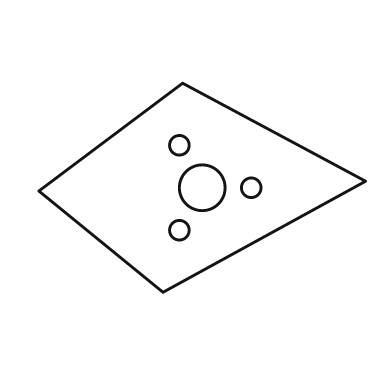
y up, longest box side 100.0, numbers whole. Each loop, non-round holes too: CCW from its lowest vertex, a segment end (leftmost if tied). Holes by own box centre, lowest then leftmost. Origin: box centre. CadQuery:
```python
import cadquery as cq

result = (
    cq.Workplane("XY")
    .moveTo(-12.0, -32.0)
    .lineTo(50.0, 2.0)
    .lineTo(-6.0, 32.0)
    .lineTo(-50.0, -1.0)
    .close()
    .moveTo(-7.0, -13.0)
    .circle(3.0)
    .moveTo(0.0, 0.0)
    .circle(7.0)
    .moveTo(15.0, 0.0)
    .circle(3.0)
    .moveTo(-7.0, 13.0)
    .circle(3.0)
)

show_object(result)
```